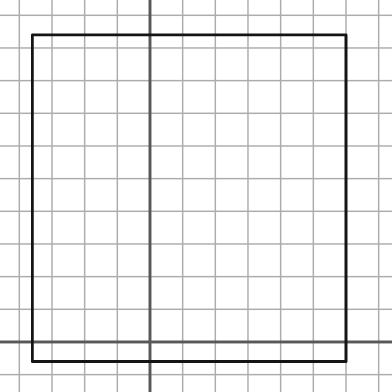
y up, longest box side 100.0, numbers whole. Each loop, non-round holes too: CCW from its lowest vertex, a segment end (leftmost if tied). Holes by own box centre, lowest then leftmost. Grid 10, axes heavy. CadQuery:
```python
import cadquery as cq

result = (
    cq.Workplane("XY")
    .moveTo(-36.0, -6.0)
    .lineTo(60.0, -6.0)
    .lineTo(60.0, 94.0)
    .lineTo(-36.0, 94.0)
    .close()
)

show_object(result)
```